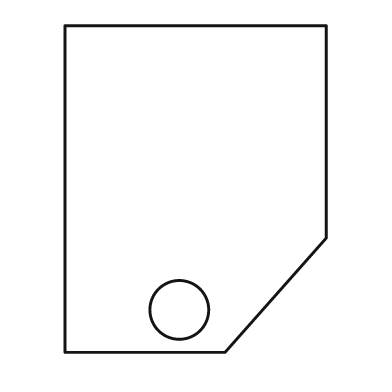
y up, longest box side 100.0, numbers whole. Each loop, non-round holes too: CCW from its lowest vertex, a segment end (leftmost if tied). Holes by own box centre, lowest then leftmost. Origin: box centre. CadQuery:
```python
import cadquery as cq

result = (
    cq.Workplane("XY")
    .moveTo(-40.0, -50.0)
    .lineTo(9.0, -50.0)
    .lineTo(40.0, -15.0)
    .lineTo(40.0, 50.0)
    .lineTo(-40.0, 50.0)
    .close()
    .moveTo(-5.0, -37.0)
    .circle(9.0)
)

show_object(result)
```